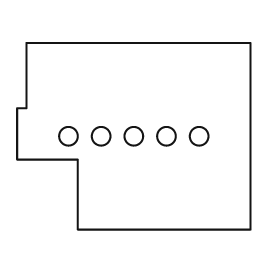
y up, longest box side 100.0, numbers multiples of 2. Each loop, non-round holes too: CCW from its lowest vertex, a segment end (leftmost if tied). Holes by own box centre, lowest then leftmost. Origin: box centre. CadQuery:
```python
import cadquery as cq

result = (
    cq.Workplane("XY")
    .moveTo(-24.0, -40.0)
    .lineTo(50.0, -40.0)
    .lineTo(50.0, 40.0)
    .lineTo(-46.0, 40.0)
    .lineTo(-46.0, 12.0)
    .lineTo(-50.0, 12.0)
    .lineTo(-50.0, -10.0)
    .lineTo(-24.0, -10.0)
    .close()
    .moveTo(-28.0, 0.0)
    .circle(4.0)
    .moveTo(-14.0, 0.0)
    .circle(4.0)
    .moveTo(0.0, 0.0)
    .circle(4.0)
    .moveTo(14.0, 0.0)
    .circle(4.0)
    .moveTo(28.0, 0.0)
    .circle(4.0)
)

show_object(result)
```